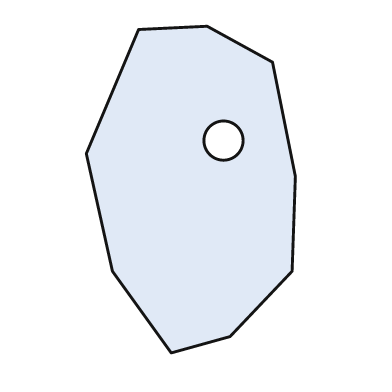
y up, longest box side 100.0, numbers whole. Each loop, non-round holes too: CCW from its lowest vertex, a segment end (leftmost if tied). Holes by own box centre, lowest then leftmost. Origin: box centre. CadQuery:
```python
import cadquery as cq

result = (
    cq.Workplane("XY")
    .moveTo(-6.0, -50.0)
    .lineTo(12.0, -45.0)
    .lineTo(31.0, -25.0)
    .lineTo(32.0, 4.0)
    .lineTo(25.0, 39.0)
    .lineTo(5.0, 50.0)
    .lineTo(-16.0, 49.0)
    .lineTo(-32.0, 11.0)
    .lineTo(-24.0, -25.0)
    .close()
    .moveTo(10.0, 15.0)
    .circle(6.0)
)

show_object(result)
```